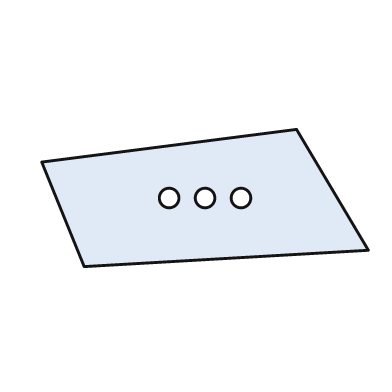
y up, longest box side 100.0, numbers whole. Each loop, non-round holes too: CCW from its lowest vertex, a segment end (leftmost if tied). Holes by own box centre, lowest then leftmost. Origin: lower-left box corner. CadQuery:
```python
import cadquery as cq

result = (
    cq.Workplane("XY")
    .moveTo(13.0, 0.0)
    .lineTo(100.0, 5.0)
    .lineTo(78.0, 42.0)
    .lineTo(0.0, 32.0)
    .close()
    .moveTo(39.0, 21.0)
    .circle(3.0)
    .moveTo(50.0, 21.0)
    .circle(3.0)
    .moveTo(61.0, 21.0)
    .circle(3.0)
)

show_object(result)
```